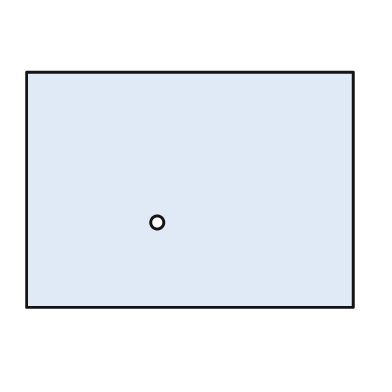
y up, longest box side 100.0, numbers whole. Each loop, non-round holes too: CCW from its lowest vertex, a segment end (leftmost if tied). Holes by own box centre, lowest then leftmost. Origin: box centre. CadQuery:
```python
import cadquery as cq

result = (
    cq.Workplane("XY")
    .moveTo(-50.0, -36.0)
    .lineTo(50.0, -36.0)
    .lineTo(50.0, 36.0)
    .lineTo(-50.0, 36.0)
    .close()
    .moveTo(-10.0, -10.0)
    .circle(2.0)
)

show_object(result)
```